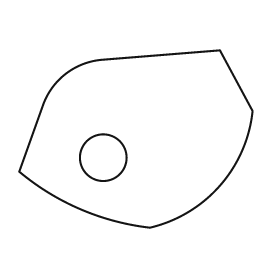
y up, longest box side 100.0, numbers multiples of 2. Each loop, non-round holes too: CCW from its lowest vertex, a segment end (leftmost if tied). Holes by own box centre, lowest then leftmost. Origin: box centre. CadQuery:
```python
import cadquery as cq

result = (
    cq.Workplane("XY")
    .moveTo(6.0, -38.0)
    .threePointArc((36.0, -20.0), (50.0, 12.0))
    .lineTo(36.0, 38.0)
    .lineTo(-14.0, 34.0)
    .threePointArc((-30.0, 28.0), (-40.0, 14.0))
    .lineTo(-50.0, -14.0)
    .threePointArc((-24.0, -30.0), (6.0, -38.0))
    .close()
    .moveTo(-14.0, -8.0)
    .circle(10.0)
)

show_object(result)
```